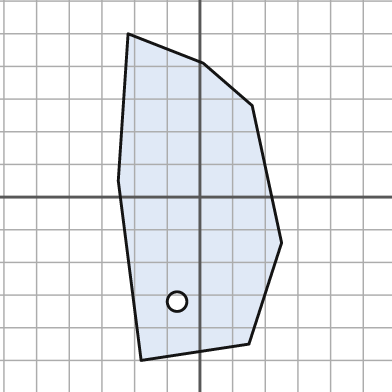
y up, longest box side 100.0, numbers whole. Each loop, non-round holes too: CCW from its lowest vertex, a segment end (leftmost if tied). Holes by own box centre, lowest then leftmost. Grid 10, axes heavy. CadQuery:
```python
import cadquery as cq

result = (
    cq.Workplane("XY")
    .moveTo(-18.0, -50.0)
    .lineTo(15.0, -45.0)
    .lineTo(25.0, -14.0)
    .lineTo(16.0, 28.0)
    .lineTo(1.0, 41.0)
    .lineTo(-22.0, 50.0)
    .lineTo(-25.0, 5.0)
    .close()
    .moveTo(-7.0, -32.0)
    .circle(3.0)
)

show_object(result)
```